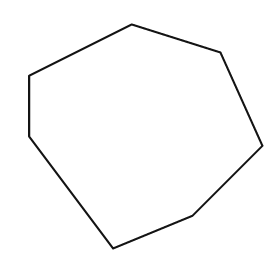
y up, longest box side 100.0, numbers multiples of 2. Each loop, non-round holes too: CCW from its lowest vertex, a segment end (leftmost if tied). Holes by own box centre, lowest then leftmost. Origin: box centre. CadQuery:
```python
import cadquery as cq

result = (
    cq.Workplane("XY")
    .moveTo(-14.0, -48.0)
    .lineTo(20.0, -34.0)
    .lineTo(50.0, -4.0)
    .lineTo(32.0, 36.0)
    .lineTo(-6.0, 48.0)
    .lineTo(-50.0, 26.0)
    .lineTo(-50.0, 0.0)
    .close()
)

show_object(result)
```